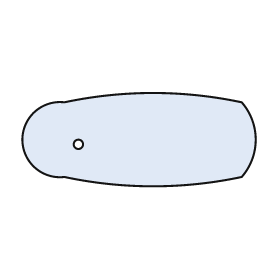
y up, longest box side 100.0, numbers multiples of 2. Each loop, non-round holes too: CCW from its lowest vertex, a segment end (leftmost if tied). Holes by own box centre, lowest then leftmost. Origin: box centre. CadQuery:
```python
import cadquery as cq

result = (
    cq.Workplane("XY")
    .moveTo(-32.0, -16.0)
    .threePointArc((6.0, -20.0), (44.0, -16.0))
    .threePointArc((50.0, 0.0), (44.0, 16.0))
    .threePointArc((6.0, 20.0), (-32.0, 16.0))
    .threePointArc((-50.0, 0.0), (-32.0, -16.0))
    .close()
    .moveTo(-26.0, -2.0)
    .circle(2.0)
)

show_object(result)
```